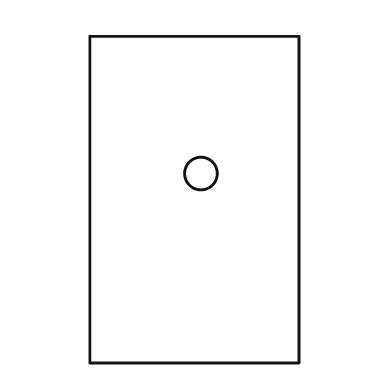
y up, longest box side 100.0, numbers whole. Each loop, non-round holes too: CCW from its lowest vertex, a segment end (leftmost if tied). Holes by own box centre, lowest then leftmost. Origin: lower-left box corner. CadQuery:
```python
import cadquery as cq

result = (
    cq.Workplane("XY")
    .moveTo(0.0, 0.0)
    .lineTo(64.0, 0.0)
    .lineTo(64.0, 100.0)
    .lineTo(0.0, 100.0)
    .close()
    .moveTo(34.0, 58.0)
    .circle(5.0)
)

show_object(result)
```